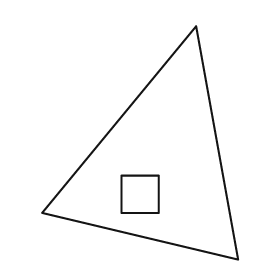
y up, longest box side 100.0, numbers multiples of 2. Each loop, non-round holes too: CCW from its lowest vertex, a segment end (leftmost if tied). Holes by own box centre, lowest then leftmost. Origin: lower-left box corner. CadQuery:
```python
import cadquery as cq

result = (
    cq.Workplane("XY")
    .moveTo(84.0, 0.0)
    .lineTo(66.0, 100.0)
    .lineTo(0.0, 20.0)
    .close()
    .moveTo(34.0, 20.0)
    .lineTo(50.0, 20.0)
    .lineTo(50.0, 36.0)
    .lineTo(34.0, 36.0)
    .close()
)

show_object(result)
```